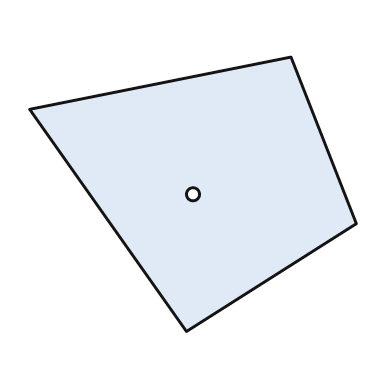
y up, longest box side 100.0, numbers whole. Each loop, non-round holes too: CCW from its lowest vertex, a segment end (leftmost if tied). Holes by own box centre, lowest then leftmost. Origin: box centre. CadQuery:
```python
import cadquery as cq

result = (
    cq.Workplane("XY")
    .moveTo(-2.0, -42.0)
    .lineTo(50.0, -9.0)
    .lineTo(30.0, 42.0)
    .lineTo(-50.0, 26.0)
    .close()
    .moveTo(0.0, 0.0)
    .circle(2.0)
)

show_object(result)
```